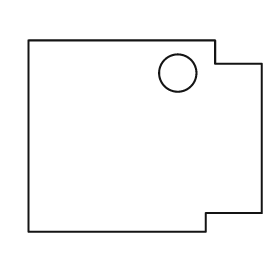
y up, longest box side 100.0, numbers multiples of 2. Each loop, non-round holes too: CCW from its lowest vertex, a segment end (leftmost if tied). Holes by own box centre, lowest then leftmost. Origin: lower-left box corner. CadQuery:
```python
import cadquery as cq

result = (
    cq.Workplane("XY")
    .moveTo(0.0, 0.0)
    .lineTo(76.0, 0.0)
    .lineTo(76.0, 8.0)
    .lineTo(100.0, 8.0)
    .lineTo(100.0, 72.0)
    .lineTo(80.0, 72.0)
    .lineTo(80.0, 82.0)
    .lineTo(0.0, 82.0)
    .close()
    .moveTo(64.0, 68.0)
    .circle(8.0)
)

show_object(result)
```